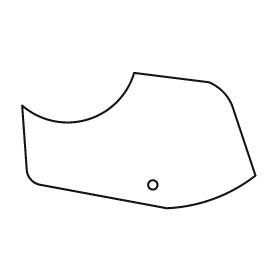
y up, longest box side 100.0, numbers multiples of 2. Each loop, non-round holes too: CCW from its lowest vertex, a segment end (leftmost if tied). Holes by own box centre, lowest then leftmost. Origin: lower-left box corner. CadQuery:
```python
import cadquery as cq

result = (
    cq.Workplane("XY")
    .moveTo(62.0, 0.0)
    .threePointArc((82.0, 4.0), (100.0, 14.0))
    .lineTo(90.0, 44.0)
    .threePointArc((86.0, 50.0), (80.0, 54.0))
    .lineTo(48.0, 58.0)
    .threePointArc((28.0, 38.0), (0.0, 44.0))
    .lineTo(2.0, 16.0)
    .threePointArc((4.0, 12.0), (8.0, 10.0))
    .close()
    .moveTo(56.0, 10.0)
    .circle(2.0)
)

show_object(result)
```